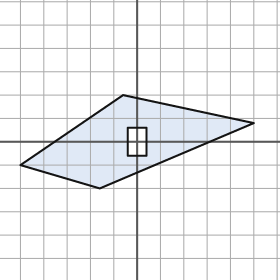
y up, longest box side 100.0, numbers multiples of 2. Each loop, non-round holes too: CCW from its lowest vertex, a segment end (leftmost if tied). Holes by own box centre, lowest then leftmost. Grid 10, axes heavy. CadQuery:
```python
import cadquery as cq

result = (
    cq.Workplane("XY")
    .moveTo(-16.0, -20.0)
    .lineTo(50.0, 8.0)
    .lineTo(-6.0, 20.0)
    .lineTo(-50.0, -10.0)
    .close()
    .moveTo(-4.0, -6.0)
    .lineTo(4.0, -6.0)
    .lineTo(4.0, 6.0)
    .lineTo(-4.0, 6.0)
    .close()
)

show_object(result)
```